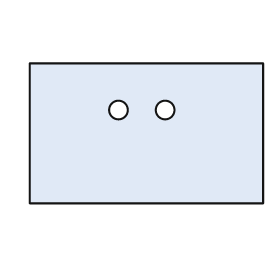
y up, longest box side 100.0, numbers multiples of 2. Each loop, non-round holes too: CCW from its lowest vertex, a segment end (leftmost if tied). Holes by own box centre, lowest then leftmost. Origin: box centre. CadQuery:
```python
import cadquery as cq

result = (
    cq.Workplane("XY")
    .moveTo(-50.0, -30.0)
    .lineTo(50.0, -30.0)
    .lineTo(50.0, 30.0)
    .lineTo(-50.0, 30.0)
    .close()
    .moveTo(-12.0, 10.0)
    .circle(4.0)
    .moveTo(8.0, 10.0)
    .circle(4.0)
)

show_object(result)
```